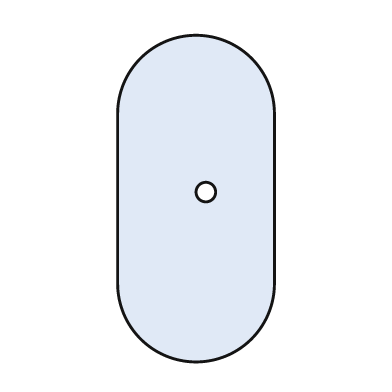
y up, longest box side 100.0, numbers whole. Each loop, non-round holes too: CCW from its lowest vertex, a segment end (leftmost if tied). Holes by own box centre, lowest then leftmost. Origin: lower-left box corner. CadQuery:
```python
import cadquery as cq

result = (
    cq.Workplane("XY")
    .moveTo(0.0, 24.0)
    .threePointArc((24.0, 0.0), (48.0, 24.0))
    .lineTo(48.0, 76.0)
    .threePointArc((24.0, 100.0), (0.0, 76.0))
    .close()
    .moveTo(27.0, 52.0)
    .circle(3.0)
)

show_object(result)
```